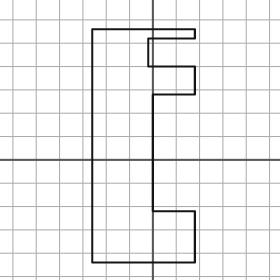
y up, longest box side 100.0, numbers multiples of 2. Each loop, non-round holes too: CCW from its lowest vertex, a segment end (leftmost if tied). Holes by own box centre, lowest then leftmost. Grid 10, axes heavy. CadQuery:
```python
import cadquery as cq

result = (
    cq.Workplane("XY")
    .moveTo(-26.0, -44.0)
    .lineTo(18.0, -44.0)
    .lineTo(18.0, -22.0)
    .lineTo(0.0, -22.0)
    .lineTo(0.0, 28.0)
    .lineTo(18.0, 28.0)
    .lineTo(18.0, 40.0)
    .lineTo(-2.0, 40.0)
    .lineTo(-2.0, 52.0)
    .lineTo(18.0, 52.0)
    .lineTo(18.0, 56.0)
    .lineTo(-26.0, 56.0)
    .close()
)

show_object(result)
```